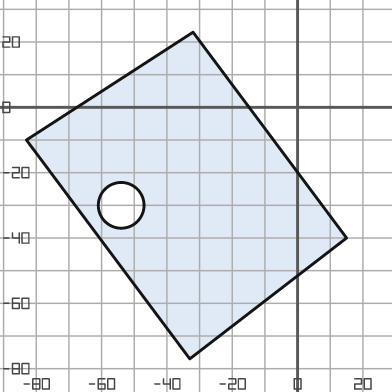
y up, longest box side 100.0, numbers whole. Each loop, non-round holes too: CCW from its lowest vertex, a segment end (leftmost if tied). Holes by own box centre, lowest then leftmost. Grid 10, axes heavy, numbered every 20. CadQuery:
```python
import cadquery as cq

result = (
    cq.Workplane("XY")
    .moveTo(-33.0, -77.0)
    .lineTo(15.0, -40.0)
    .lineTo(-32.0, 23.0)
    .lineTo(-83.0, -10.0)
    .close()
    .moveTo(-54.0, -30.0)
    .circle(7.0)
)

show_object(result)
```